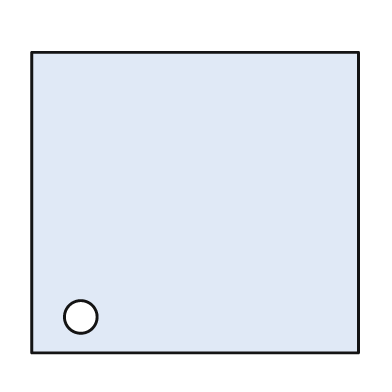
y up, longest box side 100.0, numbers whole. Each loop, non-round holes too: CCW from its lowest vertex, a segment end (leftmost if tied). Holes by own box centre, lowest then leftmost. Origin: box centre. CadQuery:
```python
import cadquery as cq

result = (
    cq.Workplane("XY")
    .moveTo(-50.0, -46.0)
    .lineTo(50.0, -46.0)
    .lineTo(50.0, 46.0)
    .lineTo(-50.0, 46.0)
    .close()
    .moveTo(-35.0, -35.0)
    .circle(5.0)
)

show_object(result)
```